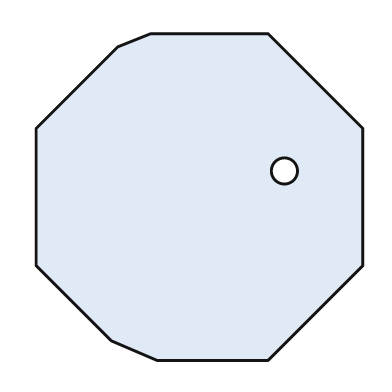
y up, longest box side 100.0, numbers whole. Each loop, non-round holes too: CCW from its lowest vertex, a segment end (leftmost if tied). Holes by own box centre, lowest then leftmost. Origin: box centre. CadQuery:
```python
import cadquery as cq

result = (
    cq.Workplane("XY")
    .moveTo(-13.0, -50.0)
    .lineTo(21.0, -50.0)
    .lineTo(50.0, -21.0)
    .lineTo(50.0, 21.0)
    .lineTo(21.0, 50.0)
    .lineTo(-15.0, 50.0)
    .lineTo(-25.0, 46.0)
    .lineTo(-50.0, 21.0)
    .lineTo(-50.0, -21.0)
    .lineTo(-27.0, -44.0)
    .close()
    .moveTo(26.0, 8.0)
    .circle(4.0)
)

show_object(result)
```